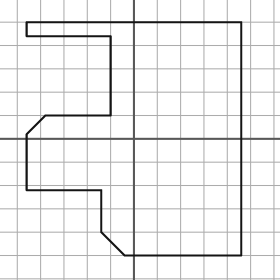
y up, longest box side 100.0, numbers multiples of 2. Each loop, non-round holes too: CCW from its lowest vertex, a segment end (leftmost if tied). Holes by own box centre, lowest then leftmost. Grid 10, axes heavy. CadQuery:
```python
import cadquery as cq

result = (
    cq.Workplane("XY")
    .moveTo(-4.0, -50.0)
    .lineTo(46.0, -50.0)
    .lineTo(46.0, 50.0)
    .lineTo(-46.0, 50.0)
    .lineTo(-46.0, 44.0)
    .lineTo(-10.0, 44.0)
    .lineTo(-10.0, 10.0)
    .lineTo(-38.0, 10.0)
    .lineTo(-46.0, 2.0)
    .lineTo(-46.0, -22.0)
    .lineTo(-14.0, -22.0)
    .lineTo(-14.0, -40.0)
    .close()
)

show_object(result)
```